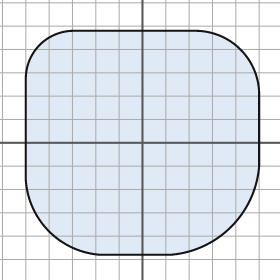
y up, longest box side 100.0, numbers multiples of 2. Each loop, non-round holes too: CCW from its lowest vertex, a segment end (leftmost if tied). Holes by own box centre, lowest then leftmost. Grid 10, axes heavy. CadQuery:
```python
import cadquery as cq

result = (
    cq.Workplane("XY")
    .moveTo(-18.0, -48.0)
    .lineTo(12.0, -48.0)
    .threePointArc((38.0, -36.0), (50.0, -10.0))
    .lineTo(50.0, 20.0)
    .threePointArc((42.0, 40.0), (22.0, 48.0))
    .lineTo(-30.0, 48.0)
    .threePointArc((-44.0, 42.0), (-50.0, 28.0))
    .lineTo(-50.0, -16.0)
    .threePointArc((-40.0, -38.0), (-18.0, -48.0))
    .close()
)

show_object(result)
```